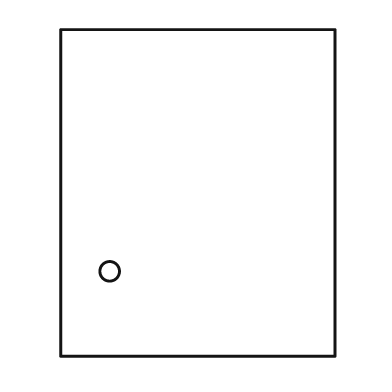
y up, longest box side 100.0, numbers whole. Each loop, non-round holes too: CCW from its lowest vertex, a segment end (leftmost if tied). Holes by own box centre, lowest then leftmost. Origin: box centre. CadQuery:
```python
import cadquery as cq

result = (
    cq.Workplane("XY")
    .moveTo(-42.0, -50.0)
    .lineTo(42.0, -50.0)
    .lineTo(42.0, 50.0)
    .lineTo(-42.0, 50.0)
    .close()
    .moveTo(-27.0, -24.0)
    .circle(3.0)
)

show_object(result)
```